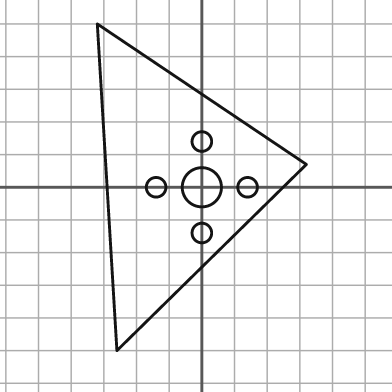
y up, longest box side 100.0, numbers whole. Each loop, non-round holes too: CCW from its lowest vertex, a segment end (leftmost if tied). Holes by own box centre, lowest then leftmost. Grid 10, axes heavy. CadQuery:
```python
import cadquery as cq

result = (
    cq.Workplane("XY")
    .moveTo(-26.0, -50.0)
    .lineTo(32.0, 7.0)
    .lineTo(-32.0, 50.0)
    .close()
    .moveTo(0.0, -14.0)
    .circle(3.0)
    .moveTo(-14.0, 0.0)
    .circle(3.0)
    .moveTo(0.0, 0.0)
    .circle(6.0)
    .moveTo(14.0, 0.0)
    .circle(3.0)
    .moveTo(0.0, 14.0)
    .circle(3.0)
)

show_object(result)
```